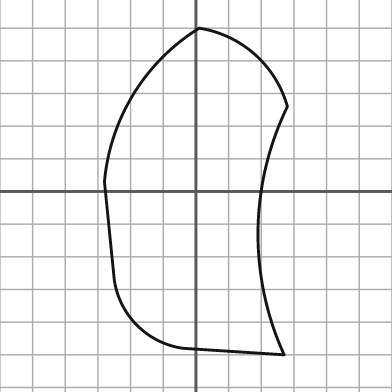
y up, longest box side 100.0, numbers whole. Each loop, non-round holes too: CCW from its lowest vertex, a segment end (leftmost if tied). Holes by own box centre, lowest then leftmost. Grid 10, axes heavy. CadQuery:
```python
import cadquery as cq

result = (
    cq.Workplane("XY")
    .moveTo(27.0, -50.0)
    .threePointArc((19.0, -12.0), (28.0, 26.0))
    .threePointArc((18.0, 42.0), (1.0, 50.0))
    .threePointArc((-19.0, 30.0), (-28.0, 3.0))
    .lineTo(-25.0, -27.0)
    .threePointArc((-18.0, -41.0), (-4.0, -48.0))
    .close()
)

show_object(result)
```